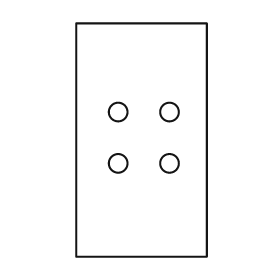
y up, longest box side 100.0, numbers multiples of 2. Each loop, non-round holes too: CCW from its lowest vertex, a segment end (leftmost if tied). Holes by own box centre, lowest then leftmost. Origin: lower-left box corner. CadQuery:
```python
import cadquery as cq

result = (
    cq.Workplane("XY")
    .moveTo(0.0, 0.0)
    .lineTo(56.0, 0.0)
    .lineTo(56.0, 100.0)
    .lineTo(0.0, 100.0)
    .close()
    .moveTo(18.0, 40.0)
    .circle(4.0)
    .moveTo(40.0, 40.0)
    .circle(4.0)
    .moveTo(18.0, 62.0)
    .circle(4.0)
    .moveTo(40.0, 62.0)
    .circle(4.0)
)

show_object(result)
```